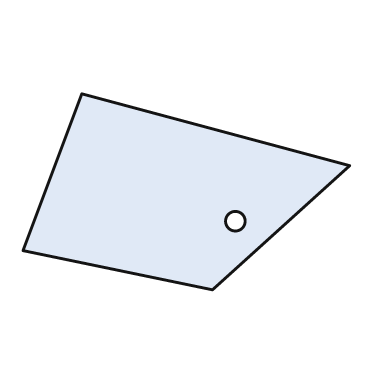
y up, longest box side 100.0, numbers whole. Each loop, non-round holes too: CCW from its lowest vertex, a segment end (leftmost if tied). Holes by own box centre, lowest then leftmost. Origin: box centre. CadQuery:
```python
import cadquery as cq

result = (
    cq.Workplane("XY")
    .moveTo(8.0, -30.0)
    .lineTo(50.0, 8.0)
    .lineTo(-32.0, 30.0)
    .lineTo(-50.0, -18.0)
    .close()
    .moveTo(15.0, -9.0)
    .circle(3.0)
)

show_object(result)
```